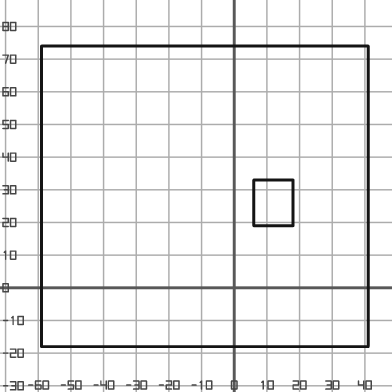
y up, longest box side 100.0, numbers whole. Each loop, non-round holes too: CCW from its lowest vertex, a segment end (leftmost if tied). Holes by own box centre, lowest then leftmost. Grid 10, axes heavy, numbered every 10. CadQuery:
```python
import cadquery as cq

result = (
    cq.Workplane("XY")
    .moveTo(-59.0, -18.0)
    .lineTo(41.0, -18.0)
    .lineTo(41.0, 74.0)
    .lineTo(-59.0, 74.0)
    .close()
    .moveTo(6.0, 19.0)
    .lineTo(18.0, 19.0)
    .lineTo(18.0, 33.0)
    .lineTo(6.0, 33.0)
    .close()
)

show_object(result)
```